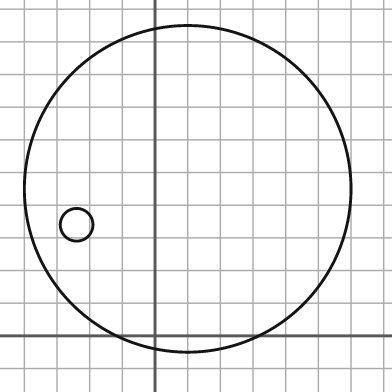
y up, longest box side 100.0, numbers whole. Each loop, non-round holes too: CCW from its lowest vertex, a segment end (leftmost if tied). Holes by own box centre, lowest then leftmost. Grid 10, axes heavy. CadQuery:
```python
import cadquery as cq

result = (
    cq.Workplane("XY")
    .moveTo(10.0, 45.0)
    .circle(50.0)
    .moveTo(-24.0, 34.0)
    .circle(5.0)
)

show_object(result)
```